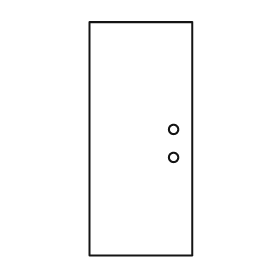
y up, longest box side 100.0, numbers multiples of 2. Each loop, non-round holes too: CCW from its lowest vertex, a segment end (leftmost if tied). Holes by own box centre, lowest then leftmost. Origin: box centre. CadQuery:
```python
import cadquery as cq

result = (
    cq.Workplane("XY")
    .moveTo(-22.0, -50.0)
    .lineTo(22.0, -50.0)
    .lineTo(22.0, 50.0)
    .lineTo(-22.0, 50.0)
    .close()
    .moveTo(14.0, -8.0)
    .circle(2.0)
    .moveTo(14.0, 4.0)
    .circle(2.0)
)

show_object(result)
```